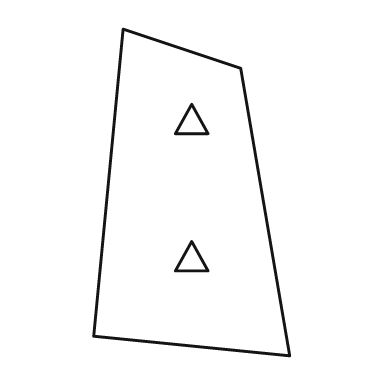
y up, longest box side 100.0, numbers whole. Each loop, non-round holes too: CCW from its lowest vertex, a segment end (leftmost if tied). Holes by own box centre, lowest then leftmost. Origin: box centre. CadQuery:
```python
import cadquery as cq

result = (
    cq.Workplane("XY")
    .moveTo(30.0, -50.0)
    .lineTo(15.0, 38.0)
    .lineTo(-21.0, 50.0)
    .lineTo(-30.0, -44.0)
    .close()
    .moveTo(-5.0, -24.0)
    .lineTo(5.0, -24.0)
    .lineTo(0.0, -15.0)
    .close()
    .moveTo(-5.0, 18.0)
    .lineTo(5.0, 18.0)
    .lineTo(0.0, 27.0)
    .close()
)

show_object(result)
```